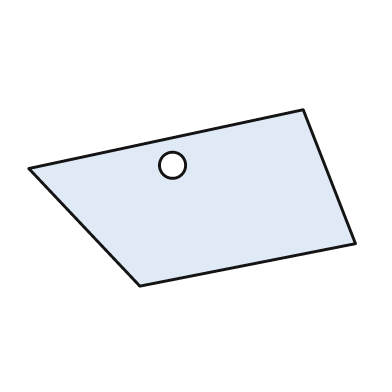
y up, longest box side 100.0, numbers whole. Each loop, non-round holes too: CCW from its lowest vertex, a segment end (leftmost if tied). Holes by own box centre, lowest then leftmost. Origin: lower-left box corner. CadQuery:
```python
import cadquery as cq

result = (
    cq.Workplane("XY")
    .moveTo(34.0, 0.0)
    .lineTo(100.0, 13.0)
    .lineTo(84.0, 54.0)
    .lineTo(0.0, 36.0)
    .close()
    .moveTo(44.0, 37.0)
    .circle(4.0)
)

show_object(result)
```